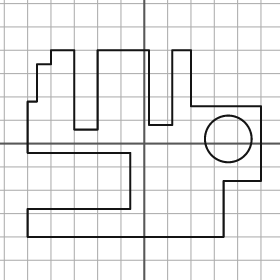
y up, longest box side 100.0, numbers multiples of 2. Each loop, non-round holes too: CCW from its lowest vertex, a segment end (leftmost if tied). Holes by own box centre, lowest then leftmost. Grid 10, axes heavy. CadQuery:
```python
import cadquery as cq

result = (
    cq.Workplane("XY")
    .moveTo(-50.0, -40.0)
    .lineTo(34.0, -40.0)
    .lineTo(34.0, -16.0)
    .lineTo(50.0, -16.0)
    .lineTo(50.0, 16.0)
    .lineTo(20.0, 16.0)
    .lineTo(20.0, 40.0)
    .lineTo(12.0, 40.0)
    .lineTo(12.0, 8.0)
    .lineTo(2.0, 8.0)
    .lineTo(2.0, 40.0)
    .lineTo(-20.0, 40.0)
    .lineTo(-20.0, 6.0)
    .lineTo(-30.0, 6.0)
    .lineTo(-30.0, 40.0)
    .lineTo(-40.0, 40.0)
    .lineTo(-40.0, 34.0)
    .lineTo(-46.0, 34.0)
    .lineTo(-46.0, 18.0)
    .lineTo(-50.0, 18.0)
    .lineTo(-50.0, -4.0)
    .lineTo(-6.0, -4.0)
    .lineTo(-6.0, -28.0)
    .lineTo(-50.0, -28.0)
    .close()
    .moveTo(36.0, 2.0)
    .circle(10.0)
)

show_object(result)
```